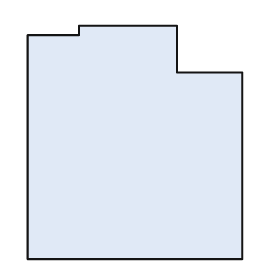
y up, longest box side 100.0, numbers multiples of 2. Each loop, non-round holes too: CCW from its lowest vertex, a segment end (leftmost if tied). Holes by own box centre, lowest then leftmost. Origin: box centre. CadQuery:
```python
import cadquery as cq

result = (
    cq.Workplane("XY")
    .moveTo(-46.0, -50.0)
    .lineTo(46.0, -50.0)
    .lineTo(46.0, 30.0)
    .lineTo(18.0, 30.0)
    .lineTo(18.0, 50.0)
    .lineTo(-24.0, 50.0)
    .lineTo(-24.0, 46.0)
    .lineTo(-46.0, 46.0)
    .close()
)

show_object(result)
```